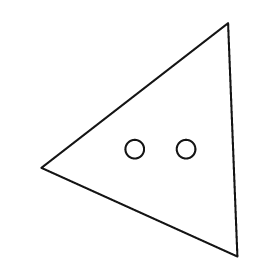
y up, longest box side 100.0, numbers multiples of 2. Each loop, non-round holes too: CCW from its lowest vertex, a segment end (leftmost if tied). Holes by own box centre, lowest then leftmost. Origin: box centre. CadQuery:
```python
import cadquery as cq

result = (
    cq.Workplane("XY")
    .moveTo(42.0, -50.0)
    .lineTo(38.0, 50.0)
    .lineTo(-42.0, -12.0)
    .close()
    .moveTo(-2.0, -4.0)
    .circle(4.0)
    .moveTo(20.0, -4.0)
    .circle(4.0)
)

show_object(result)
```